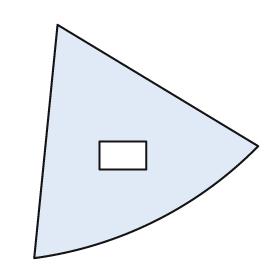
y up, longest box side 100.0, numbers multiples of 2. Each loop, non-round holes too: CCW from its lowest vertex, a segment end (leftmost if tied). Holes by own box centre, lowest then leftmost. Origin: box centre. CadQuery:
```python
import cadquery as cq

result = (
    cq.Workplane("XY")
    .moveTo(-48.0, -50.0)
    .threePointArc((4.0, -34.0), (48.0, -2.0))
    .lineTo(-38.0, 50.0)
    .close()
    .moveTo(-20.0, -12.0)
    .lineTo(0.0, -12.0)
    .lineTo(0.0, 0.0)
    .lineTo(-20.0, 0.0)
    .close()
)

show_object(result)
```